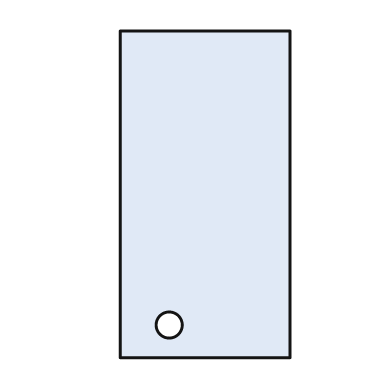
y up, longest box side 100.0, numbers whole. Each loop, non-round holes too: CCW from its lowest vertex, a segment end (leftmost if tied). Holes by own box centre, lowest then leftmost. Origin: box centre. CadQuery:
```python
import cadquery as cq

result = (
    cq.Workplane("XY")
    .moveTo(-26.0, -50.0)
    .lineTo(26.0, -50.0)
    .lineTo(26.0, 50.0)
    .lineTo(-26.0, 50.0)
    .close()
    .moveTo(-11.0, -40.0)
    .circle(4.0)
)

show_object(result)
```